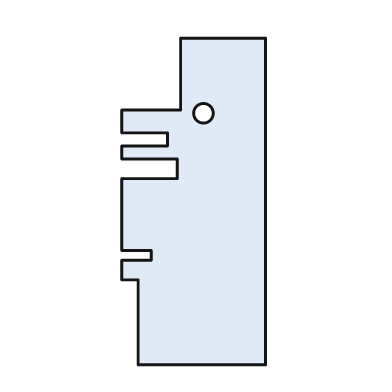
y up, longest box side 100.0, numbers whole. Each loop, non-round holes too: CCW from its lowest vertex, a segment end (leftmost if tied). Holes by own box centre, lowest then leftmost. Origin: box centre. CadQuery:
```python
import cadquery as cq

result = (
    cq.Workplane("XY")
    .moveTo(-17.0, -50.0)
    .lineTo(22.0, -50.0)
    .lineTo(22.0, 50.0)
    .lineTo(-4.0, 50.0)
    .lineTo(-4.0, 28.0)
    .lineTo(-22.0, 28.0)
    .lineTo(-22.0, 21.0)
    .lineTo(-8.0, 21.0)
    .lineTo(-8.0, 17.0)
    .lineTo(-22.0, 17.0)
    .lineTo(-22.0, 13.0)
    .lineTo(-5.0, 13.0)
    .lineTo(-5.0, 7.0)
    .lineTo(-22.0, 7.0)
    .lineTo(-22.0, -15.0)
    .lineTo(-13.0, -15.0)
    .lineTo(-13.0, -18.0)
    .lineTo(-22.0, -18.0)
    .lineTo(-22.0, -24.0)
    .lineTo(-17.0, -24.0)
    .close()
    .moveTo(3.0, 27.0)
    .circle(3.0)
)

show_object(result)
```